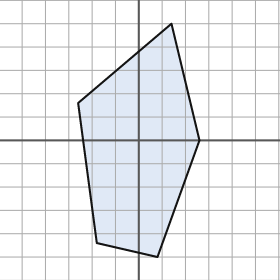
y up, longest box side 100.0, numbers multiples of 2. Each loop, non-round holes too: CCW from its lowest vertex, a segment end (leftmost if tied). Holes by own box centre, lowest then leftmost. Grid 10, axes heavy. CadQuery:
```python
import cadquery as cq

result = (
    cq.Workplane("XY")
    .moveTo(8.0, -50.0)
    .lineTo(26.0, 0.0)
    .lineTo(14.0, 50.0)
    .lineTo(-26.0, 16.0)
    .lineTo(-18.0, -44.0)
    .close()
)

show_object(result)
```